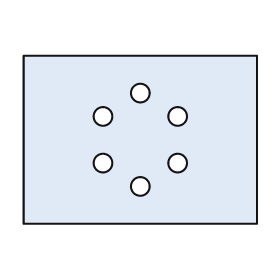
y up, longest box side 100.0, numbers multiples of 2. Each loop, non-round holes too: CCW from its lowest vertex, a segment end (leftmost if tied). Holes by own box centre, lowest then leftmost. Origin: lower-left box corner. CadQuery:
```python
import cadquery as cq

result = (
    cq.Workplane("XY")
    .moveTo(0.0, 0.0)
    .lineTo(100.0, 0.0)
    .lineTo(100.0, 72.0)
    .lineTo(0.0, 72.0)
    .close()
    .moveTo(50.0, 16.0)
    .circle(4.0)
    .moveTo(34.0, 26.0)
    .circle(4.0)
    .moveTo(66.0, 26.0)
    .circle(4.0)
    .moveTo(34.0, 46.0)
    .circle(4.0)
    .moveTo(66.0, 46.0)
    .circle(4.0)
    .moveTo(50.0, 56.0)
    .circle(4.0)
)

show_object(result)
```